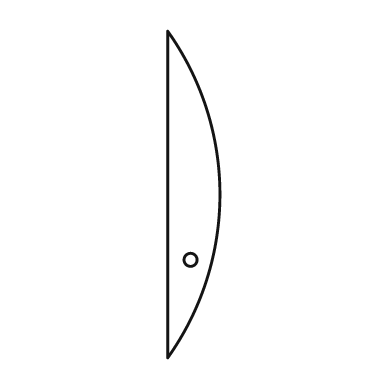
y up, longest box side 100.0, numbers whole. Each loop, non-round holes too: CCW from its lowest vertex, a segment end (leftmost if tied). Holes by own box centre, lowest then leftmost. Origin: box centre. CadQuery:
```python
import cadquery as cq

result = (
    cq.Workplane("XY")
    .moveTo(-8.0, -50.0)
    .threePointArc((8.0, 0.0), (-8.0, 50.0))
    .close()
    .moveTo(-1.0, -20.0)
    .circle(2.0)
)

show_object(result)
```